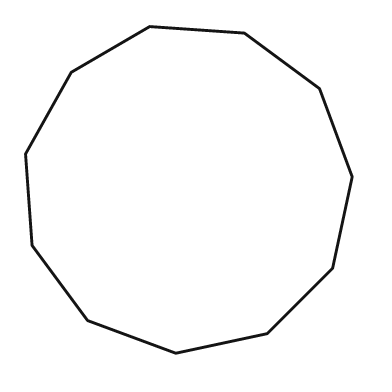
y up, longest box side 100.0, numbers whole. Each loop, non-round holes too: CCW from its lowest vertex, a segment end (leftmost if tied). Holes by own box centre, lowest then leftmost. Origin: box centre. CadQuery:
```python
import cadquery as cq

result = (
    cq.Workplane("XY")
    .moveTo(-4.0, -50.0)
    .lineTo(24.0, -44.0)
    .lineTo(44.0, -24.0)
    .lineTo(50.0, 4.0)
    .lineTo(40.0, 31.0)
    .lineTo(17.0, 48.0)
    .lineTo(-12.0, 50.0)
    .lineTo(-36.0, 36.0)
    .lineTo(-50.0, 11.0)
    .lineTo(-48.0, -17.0)
    .lineTo(-31.0, -40.0)
    .close()
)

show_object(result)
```